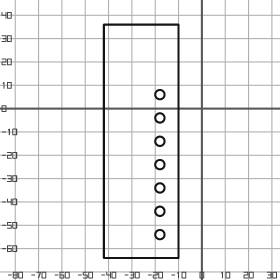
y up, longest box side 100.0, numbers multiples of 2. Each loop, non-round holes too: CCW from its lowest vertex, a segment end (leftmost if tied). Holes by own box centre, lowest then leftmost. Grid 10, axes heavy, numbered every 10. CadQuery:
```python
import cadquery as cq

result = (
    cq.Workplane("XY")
    .moveTo(-42.0, -64.0)
    .lineTo(-10.0, -64.0)
    .lineTo(-10.0, 36.0)
    .lineTo(-42.0, 36.0)
    .close()
    .moveTo(-18.0, -54.0)
    .circle(2.0)
    .moveTo(-18.0, -44.0)
    .circle(2.0)
    .moveTo(-18.0, -34.0)
    .circle(2.0)
    .moveTo(-18.0, -24.0)
    .circle(2.0)
    .moveTo(-18.0, -14.0)
    .circle(2.0)
    .moveTo(-18.0, -4.0)
    .circle(2.0)
    .moveTo(-18.0, 6.0)
    .circle(2.0)
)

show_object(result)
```